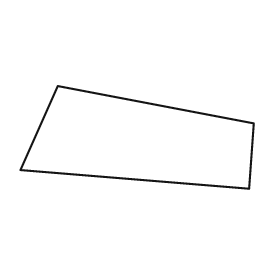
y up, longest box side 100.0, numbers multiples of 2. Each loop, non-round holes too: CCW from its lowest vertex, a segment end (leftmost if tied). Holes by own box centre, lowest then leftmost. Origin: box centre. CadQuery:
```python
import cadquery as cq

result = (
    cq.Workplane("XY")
    .moveTo(48.0, -22.0)
    .lineTo(50.0, 6.0)
    .lineTo(-34.0, 22.0)
    .lineTo(-50.0, -14.0)
    .close()
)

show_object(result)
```